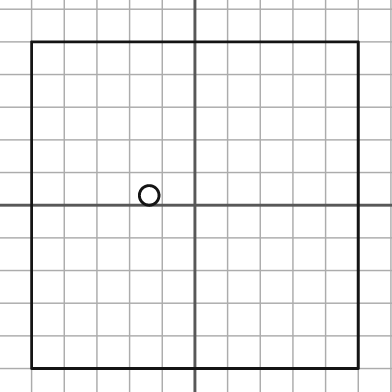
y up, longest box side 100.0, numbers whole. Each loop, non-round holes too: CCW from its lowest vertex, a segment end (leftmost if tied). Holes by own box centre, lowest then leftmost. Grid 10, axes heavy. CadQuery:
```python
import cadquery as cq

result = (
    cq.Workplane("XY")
    .moveTo(-50.0, -50.0)
    .lineTo(50.0, -50.0)
    .lineTo(50.0, 50.0)
    .lineTo(-50.0, 50.0)
    .close()
    .moveTo(-14.0, 3.0)
    .circle(3.0)
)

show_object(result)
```